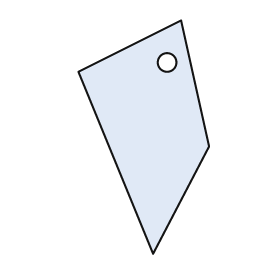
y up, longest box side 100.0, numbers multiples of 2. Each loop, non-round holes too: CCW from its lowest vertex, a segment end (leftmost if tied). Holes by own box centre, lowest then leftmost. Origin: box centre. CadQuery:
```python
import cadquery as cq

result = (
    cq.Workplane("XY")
    .moveTo(4.0, -50.0)
    .lineTo(28.0, -4.0)
    .lineTo(16.0, 50.0)
    .lineTo(-28.0, 28.0)
    .close()
    .moveTo(10.0, 32.0)
    .circle(4.0)
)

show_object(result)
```